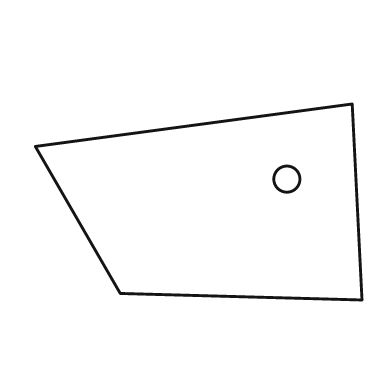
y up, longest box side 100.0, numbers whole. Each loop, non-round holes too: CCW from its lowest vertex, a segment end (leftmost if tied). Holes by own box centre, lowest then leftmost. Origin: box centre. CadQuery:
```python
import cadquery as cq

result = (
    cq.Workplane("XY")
    .moveTo(50.0, -30.0)
    .lineTo(47.0, 30.0)
    .lineTo(-50.0, 17.0)
    .lineTo(-24.0, -28.0)
    .close()
    .moveTo(27.0, 7.0)
    .circle(4.0)
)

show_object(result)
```